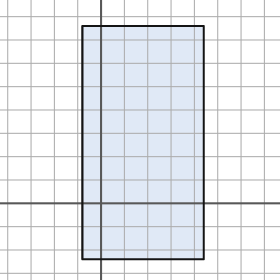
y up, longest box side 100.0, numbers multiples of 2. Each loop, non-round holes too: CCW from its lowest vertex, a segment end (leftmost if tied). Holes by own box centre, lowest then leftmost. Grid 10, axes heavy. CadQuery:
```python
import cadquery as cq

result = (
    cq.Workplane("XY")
    .moveTo(-8.0, -24.0)
    .lineTo(44.0, -24.0)
    .lineTo(44.0, 76.0)
    .lineTo(-8.0, 76.0)
    .close()
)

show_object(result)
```